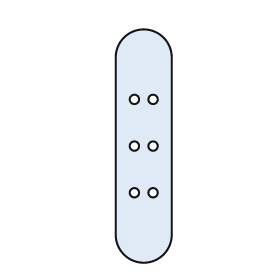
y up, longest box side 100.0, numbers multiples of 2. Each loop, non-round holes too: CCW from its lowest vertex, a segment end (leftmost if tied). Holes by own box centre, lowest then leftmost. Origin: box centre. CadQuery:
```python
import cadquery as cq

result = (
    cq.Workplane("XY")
    .moveTo(-12.0, -38.0)
    .threePointArc((0.0, -50.0), (12.0, -38.0))
    .lineTo(12.0, 38.0)
    .threePointArc((0.0, 50.0), (-12.0, 38.0))
    .close()
    .moveTo(-4.0, -20.0)
    .circle(2.0)
    .moveTo(4.0, -20.0)
    .circle(2.0)
    .moveTo(-4.0, 0.0)
    .circle(2.0)
    .moveTo(4.0, 0.0)
    .circle(2.0)
    .moveTo(-4.0, 20.0)
    .circle(2.0)
    .moveTo(4.0, 20.0)
    .circle(2.0)
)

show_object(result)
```